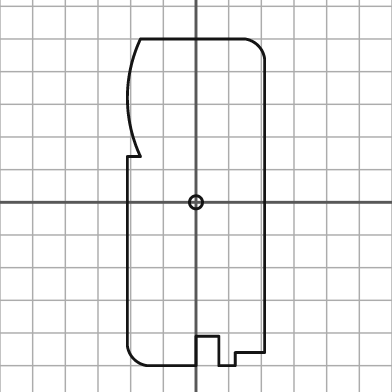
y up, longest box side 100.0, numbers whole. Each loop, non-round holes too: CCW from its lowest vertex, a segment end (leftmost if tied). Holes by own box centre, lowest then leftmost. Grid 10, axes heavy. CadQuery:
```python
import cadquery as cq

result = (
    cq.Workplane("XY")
    .moveTo(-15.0, -50.0)
    .lineTo(0.0, -50.0)
    .lineTo(0.0, -41.0)
    .lineTo(7.0, -41.0)
    .lineTo(7.0, -50.0)
    .lineTo(12.0, -50.0)
    .lineTo(12.0, -46.0)
    .lineTo(21.0, -46.0)
    .lineTo(21.0, 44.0)
    .threePointArc((19.0, 48.0), (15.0, 50.0))
    .lineTo(-17.0, 50.0)
    .threePointArc((-21.0, 32.0), (-17.0, 14.0))
    .lineTo(-21.0, 14.0)
    .lineTo(-21.0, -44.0)
    .threePointArc((-19.0, -48.0), (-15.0, -50.0))
    .close()
    .moveTo(0.0, 0.0)
    .circle(2.0)
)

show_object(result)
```